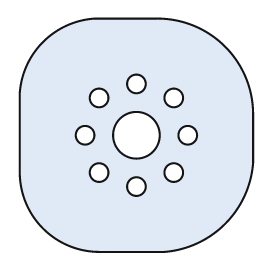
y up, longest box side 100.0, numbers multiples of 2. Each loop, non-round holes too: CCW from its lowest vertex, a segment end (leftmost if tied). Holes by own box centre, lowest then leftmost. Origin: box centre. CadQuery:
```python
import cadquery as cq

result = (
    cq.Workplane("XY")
    .moveTo(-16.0, -50.0)
    .lineTo(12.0, -50.0)
    .threePointArc((38.0, -38.0), (50.0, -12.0))
    .lineTo(50.0, 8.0)
    .threePointArc((38.0, 38.0), (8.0, 50.0))
    .lineTo(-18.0, 50.0)
    .threePointArc((-40.0, 40.0), (-50.0, 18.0))
    .lineTo(-50.0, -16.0)
    .threePointArc((-40.0, -40.0), (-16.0, -50.0))
    .close()
    .moveTo(0.0, -22.0)
    .circle(4.0)
    .moveTo(-16.0, -16.0)
    .circle(4.0)
    .moveTo(16.0, -16.0)
    .circle(4.0)
    .moveTo(-22.0, 0.0)
    .circle(4.0)
    .moveTo(0.0, 0.0)
    .circle(10.0)
    .moveTo(22.0, 0.0)
    .circle(4.0)
    .moveTo(-16.0, 16.0)
    .circle(4.0)
    .moveTo(16.0, 16.0)
    .circle(4.0)
    .moveTo(0.0, 22.0)
    .circle(4.0)
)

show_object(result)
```